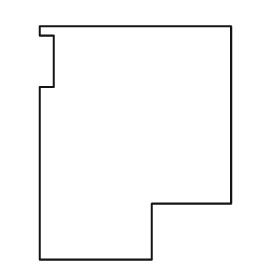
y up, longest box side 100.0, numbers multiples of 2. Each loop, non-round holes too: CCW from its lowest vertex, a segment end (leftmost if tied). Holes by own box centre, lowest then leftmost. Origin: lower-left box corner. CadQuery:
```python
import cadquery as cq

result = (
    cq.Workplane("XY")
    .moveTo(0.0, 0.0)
    .lineTo(48.0, 0.0)
    .lineTo(48.0, 24.0)
    .lineTo(82.0, 24.0)
    .lineTo(82.0, 100.0)
    .lineTo(0.0, 100.0)
    .lineTo(0.0, 96.0)
    .lineTo(6.0, 96.0)
    .lineTo(6.0, 74.0)
    .lineTo(0.0, 74.0)
    .close()
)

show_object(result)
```